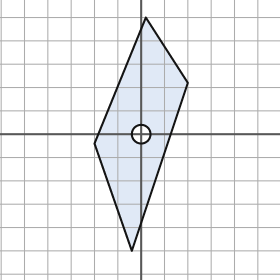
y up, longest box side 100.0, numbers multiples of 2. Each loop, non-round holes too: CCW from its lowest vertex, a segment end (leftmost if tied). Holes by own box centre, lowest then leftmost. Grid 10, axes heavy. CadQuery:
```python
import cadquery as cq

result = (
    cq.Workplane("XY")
    .moveTo(-4.0, -50.0)
    .lineTo(20.0, 22.0)
    .lineTo(2.0, 50.0)
    .lineTo(-20.0, -4.0)
    .close()
    .moveTo(0.0, 0.0)
    .circle(4.0)
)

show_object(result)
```